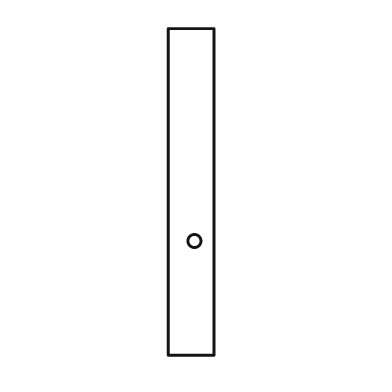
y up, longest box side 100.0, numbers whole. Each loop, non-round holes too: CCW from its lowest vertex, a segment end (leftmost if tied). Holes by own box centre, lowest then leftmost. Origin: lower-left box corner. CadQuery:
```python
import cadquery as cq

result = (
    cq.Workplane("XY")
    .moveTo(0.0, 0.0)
    .lineTo(14.0, 0.0)
    .lineTo(14.0, 100.0)
    .lineTo(0.0, 100.0)
    .close()
    .moveTo(8.0, 35.0)
    .circle(2.0)
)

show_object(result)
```